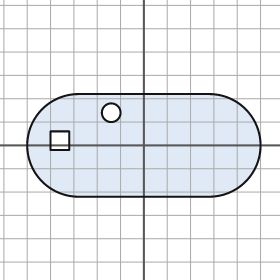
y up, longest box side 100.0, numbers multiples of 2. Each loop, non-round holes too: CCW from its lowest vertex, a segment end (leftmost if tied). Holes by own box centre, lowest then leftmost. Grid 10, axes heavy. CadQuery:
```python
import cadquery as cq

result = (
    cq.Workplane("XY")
    .moveTo(-28.0, -22.0)
    .lineTo(28.0, -22.0)
    .threePointArc((50.0, 0.0), (28.0, 22.0))
    .lineTo(-28.0, 22.0)
    .threePointArc((-50.0, 0.0), (-28.0, -22.0))
    .close()
    .moveTo(-40.0, -2.0)
    .lineTo(-32.0, -2.0)
    .lineTo(-32.0, 6.0)
    .lineTo(-40.0, 6.0)
    .close()
    .moveTo(-14.0, 14.0)
    .circle(4.0)
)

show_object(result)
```